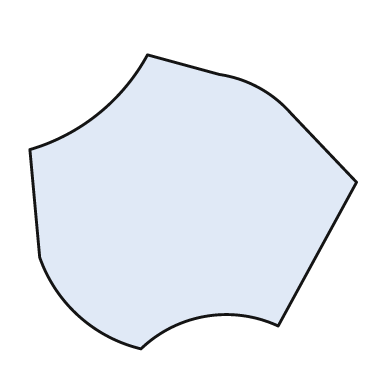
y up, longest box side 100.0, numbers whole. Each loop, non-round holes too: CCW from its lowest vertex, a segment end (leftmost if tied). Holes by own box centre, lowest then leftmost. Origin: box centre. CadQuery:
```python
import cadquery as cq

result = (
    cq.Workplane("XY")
    .moveTo(-16.0, -45.0)
    .threePointArc((4.0, -35.0), (26.0, -38.0))
    .lineTo(50.0, 6.0)
    .lineTo(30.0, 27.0)
    .threePointArc((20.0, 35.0), (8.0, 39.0))
    .lineTo(-14.0, 45.0)
    .threePointArc((-29.0, 27.0), (-50.0, 16.0))
    .lineTo(-47.0, -17.0)
    .threePointArc((-35.0, -35.0), (-16.0, -45.0))
    .close()
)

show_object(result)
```